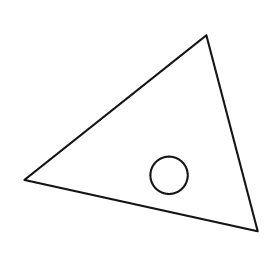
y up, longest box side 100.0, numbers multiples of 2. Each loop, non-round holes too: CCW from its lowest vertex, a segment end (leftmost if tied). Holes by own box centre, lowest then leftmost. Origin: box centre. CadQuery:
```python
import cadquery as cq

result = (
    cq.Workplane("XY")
    .moveTo(50.0, -42.0)
    .lineTo(28.0, 42.0)
    .lineTo(-50.0, -20.0)
    .close()
    .moveTo(12.0, -18.0)
    .circle(8.0)
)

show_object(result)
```